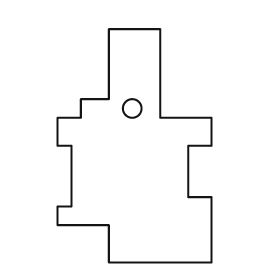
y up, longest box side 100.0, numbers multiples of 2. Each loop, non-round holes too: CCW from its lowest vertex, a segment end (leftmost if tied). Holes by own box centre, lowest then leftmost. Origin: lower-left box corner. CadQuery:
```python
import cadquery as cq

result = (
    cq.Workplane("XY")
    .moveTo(22.0, 0.0)
    .lineTo(66.0, 0.0)
    .lineTo(66.0, 28.0)
    .lineTo(56.0, 28.0)
    .lineTo(56.0, 50.0)
    .lineTo(66.0, 50.0)
    .lineTo(66.0, 62.0)
    .lineTo(44.0, 62.0)
    .lineTo(44.0, 100.0)
    .lineTo(22.0, 100.0)
    .lineTo(22.0, 70.0)
    .lineTo(10.0, 70.0)
    .lineTo(10.0, 62.0)
    .lineTo(0.0, 62.0)
    .lineTo(0.0, 50.0)
    .lineTo(6.0, 50.0)
    .lineTo(6.0, 24.0)
    .lineTo(0.0, 24.0)
    .lineTo(0.0, 16.0)
    .lineTo(22.0, 16.0)
    .close()
    .moveTo(32.0, 66.0)
    .circle(4.0)
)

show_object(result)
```